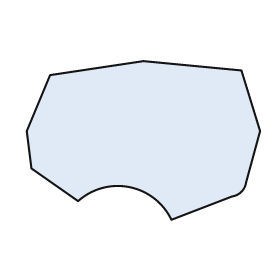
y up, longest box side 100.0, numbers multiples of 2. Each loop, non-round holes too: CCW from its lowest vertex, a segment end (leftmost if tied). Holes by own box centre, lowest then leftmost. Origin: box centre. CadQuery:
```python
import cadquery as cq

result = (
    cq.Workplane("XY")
    .moveTo(12.0, -34.0)
    .lineTo(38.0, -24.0)
    .threePointArc((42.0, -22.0), (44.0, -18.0))
    .lineTo(50.0, 4.0)
    .lineTo(42.0, 30.0)
    .lineTo(0.0, 34.0)
    .lineTo(-40.0, 28.0)
    .lineTo(-50.0, 4.0)
    .lineTo(-48.0, -12.0)
    .lineTo(-28.0, -26.0)
    .threePointArc((-6.0, -20.0), (12.0, -34.0))
    .close()
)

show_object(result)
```